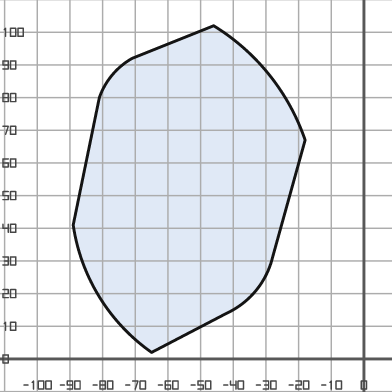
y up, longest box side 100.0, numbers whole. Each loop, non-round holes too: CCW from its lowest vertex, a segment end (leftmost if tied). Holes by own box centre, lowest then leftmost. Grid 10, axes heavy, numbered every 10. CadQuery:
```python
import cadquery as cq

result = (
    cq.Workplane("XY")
    .moveTo(-65.0, 2.0)
    .lineTo(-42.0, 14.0)
    .threePointArc((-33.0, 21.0), (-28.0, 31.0))
    .lineTo(-18.0, 67.0)
    .threePointArc((-29.0, 87.0), (-46.0, 102.0))
    .lineTo(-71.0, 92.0)
    .threePointArc((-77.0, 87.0), (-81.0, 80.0))
    .lineTo(-89.0, 41.0)
    .threePointArc((-81.0, 19.0), (-65.0, 2.0))
    .close()
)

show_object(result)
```